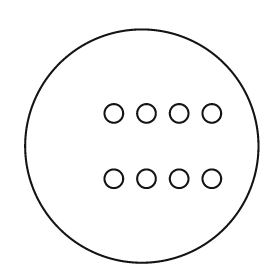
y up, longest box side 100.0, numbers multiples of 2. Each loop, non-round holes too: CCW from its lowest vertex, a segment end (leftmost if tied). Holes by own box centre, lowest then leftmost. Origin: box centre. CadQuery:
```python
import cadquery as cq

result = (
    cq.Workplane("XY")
    .moveTo(0.0, 0.0)
    .circle(50.0)
    .moveTo(-12.0, -14.0)
    .circle(4.0)
    .moveTo(2.0, -14.0)
    .circle(4.0)
    .moveTo(16.0, -14.0)
    .circle(4.0)
    .moveTo(30.0, -14.0)
    .circle(4.0)
    .moveTo(-12.0, 14.0)
    .circle(4.0)
    .moveTo(2.0, 14.0)
    .circle(4.0)
    .moveTo(16.0, 14.0)
    .circle(4.0)
    .moveTo(30.0, 14.0)
    .circle(4.0)
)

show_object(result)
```